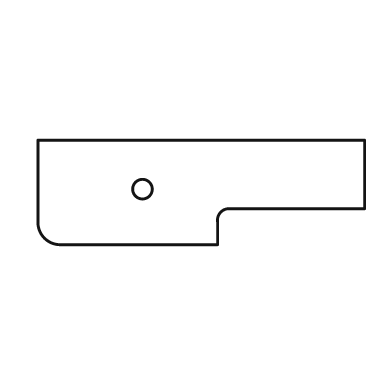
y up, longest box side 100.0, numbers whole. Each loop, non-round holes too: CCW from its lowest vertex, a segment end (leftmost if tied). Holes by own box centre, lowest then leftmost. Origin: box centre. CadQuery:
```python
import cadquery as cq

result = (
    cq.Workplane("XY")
    .moveTo(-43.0, -16.0)
    .lineTo(5.0, -16.0)
    .lineTo(5.0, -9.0)
    .threePointArc((6.0, -6.0), (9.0, -5.0))
    .lineTo(50.0, -5.0)
    .lineTo(50.0, 16.0)
    .lineTo(-50.0, 16.0)
    .lineTo(-50.0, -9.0)
    .threePointArc((-48.0, -14.0), (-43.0, -16.0))
    .close()
    .moveTo(-18.0, 1.0)
    .circle(3.0)
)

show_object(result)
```